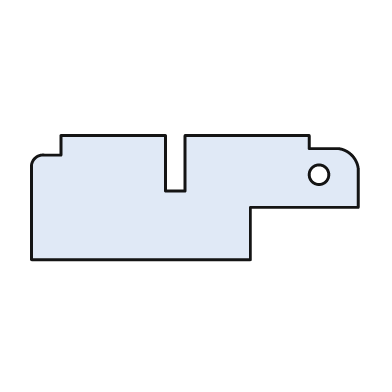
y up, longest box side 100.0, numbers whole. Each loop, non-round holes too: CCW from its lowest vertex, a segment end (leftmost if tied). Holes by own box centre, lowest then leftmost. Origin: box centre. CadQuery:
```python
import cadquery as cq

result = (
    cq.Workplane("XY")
    .moveTo(-50.0, -19.0)
    .lineTo(17.0, -19.0)
    .lineTo(17.0, -3.0)
    .lineTo(50.0, -3.0)
    .lineTo(50.0, 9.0)
    .threePointArc((48.0, 13.0), (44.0, 15.0))
    .lineTo(35.0, 15.0)
    .lineTo(35.0, 19.0)
    .lineTo(-3.0, 19.0)
    .lineTo(-3.0, 2.0)
    .lineTo(-9.0, 2.0)
    .lineTo(-9.0, 19.0)
    .lineTo(-41.0, 19.0)
    .lineTo(-41.0, 13.0)
    .lineTo(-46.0, 13.0)
    .threePointArc((-49.0, 12.0), (-50.0, 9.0))
    .close()
    .moveTo(38.0, 7.0)
    .circle(3.0)
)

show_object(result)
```